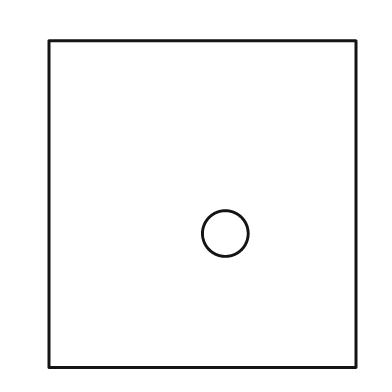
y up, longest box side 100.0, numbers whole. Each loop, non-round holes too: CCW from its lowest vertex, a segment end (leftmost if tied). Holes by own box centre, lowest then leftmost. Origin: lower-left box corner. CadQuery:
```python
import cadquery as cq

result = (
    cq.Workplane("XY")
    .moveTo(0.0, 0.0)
    .lineTo(94.0, 0.0)
    .lineTo(94.0, 100.0)
    .lineTo(0.0, 100.0)
    .close()
    .moveTo(54.0, 41.0)
    .circle(7.0)
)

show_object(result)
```